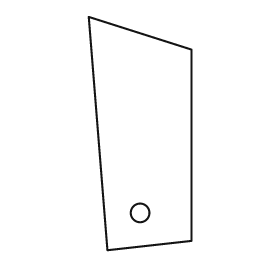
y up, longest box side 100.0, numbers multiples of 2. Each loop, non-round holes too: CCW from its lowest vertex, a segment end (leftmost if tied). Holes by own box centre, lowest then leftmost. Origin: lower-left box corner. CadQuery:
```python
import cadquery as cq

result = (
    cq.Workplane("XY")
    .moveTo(8.0, 0.0)
    .lineTo(44.0, 4.0)
    .lineTo(44.0, 86.0)
    .lineTo(0.0, 100.0)
    .close()
    .moveTo(22.0, 16.0)
    .circle(4.0)
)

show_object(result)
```